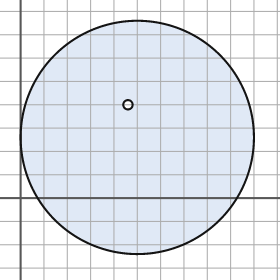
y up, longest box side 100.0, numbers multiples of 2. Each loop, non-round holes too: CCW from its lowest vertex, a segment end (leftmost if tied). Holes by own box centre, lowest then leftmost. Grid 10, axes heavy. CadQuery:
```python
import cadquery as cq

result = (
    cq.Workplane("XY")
    .moveTo(50.0, 26.0)
    .circle(50.0)
    .moveTo(46.0, 40.0)
    .circle(2.0)
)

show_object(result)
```